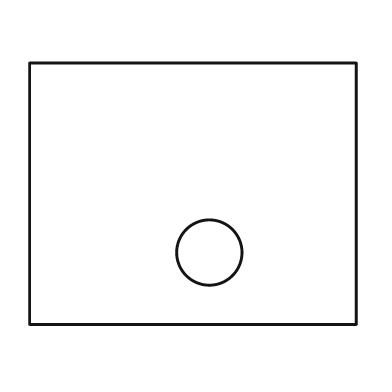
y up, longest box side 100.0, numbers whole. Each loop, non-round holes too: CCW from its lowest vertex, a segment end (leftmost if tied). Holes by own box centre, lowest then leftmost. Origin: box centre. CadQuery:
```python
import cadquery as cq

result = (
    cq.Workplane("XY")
    .moveTo(-50.0, -40.0)
    .lineTo(50.0, -40.0)
    .lineTo(50.0, 40.0)
    .lineTo(-50.0, 40.0)
    .close()
    .moveTo(5.0, -18.0)
    .circle(10.0)
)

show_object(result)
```